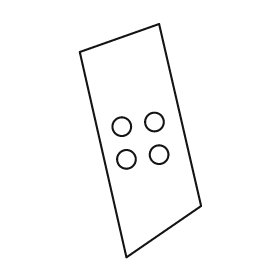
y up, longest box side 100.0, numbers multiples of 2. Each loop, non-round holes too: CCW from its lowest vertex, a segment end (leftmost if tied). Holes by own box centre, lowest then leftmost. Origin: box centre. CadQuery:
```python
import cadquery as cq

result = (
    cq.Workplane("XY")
    .moveTo(-6.0, -50.0)
    .lineTo(26.0, -28.0)
    .lineTo(8.0, 50.0)
    .lineTo(-26.0, 38.0)
    .close()
    .moveTo(-6.0, -8.0)
    .circle(4.0)
    .moveTo(8.0, -6.0)
    .circle(4.0)
    .moveTo(-8.0, 6.0)
    .circle(4.0)
    .moveTo(6.0, 8.0)
    .circle(4.0)
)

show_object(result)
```